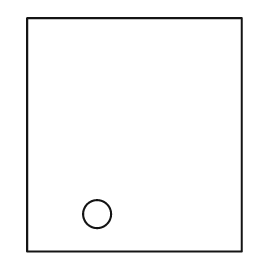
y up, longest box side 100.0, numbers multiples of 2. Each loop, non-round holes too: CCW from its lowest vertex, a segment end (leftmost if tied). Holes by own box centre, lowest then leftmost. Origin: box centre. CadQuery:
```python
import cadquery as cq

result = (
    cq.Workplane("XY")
    .moveTo(-46.0, -50.0)
    .lineTo(46.0, -50.0)
    .lineTo(46.0, 50.0)
    .lineTo(-46.0, 50.0)
    .close()
    .moveTo(-16.0, -34.0)
    .circle(6.0)
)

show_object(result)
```